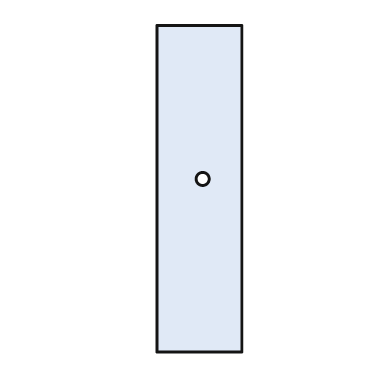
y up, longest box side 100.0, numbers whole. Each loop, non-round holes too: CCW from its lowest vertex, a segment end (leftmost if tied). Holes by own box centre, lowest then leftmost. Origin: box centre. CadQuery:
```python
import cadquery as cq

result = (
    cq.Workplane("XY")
    .moveTo(-13.0, -50.0)
    .lineTo(13.0, -50.0)
    .lineTo(13.0, 50.0)
    .lineTo(-13.0, 50.0)
    .close()
    .moveTo(1.0, 3.0)
    .circle(2.0)
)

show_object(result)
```